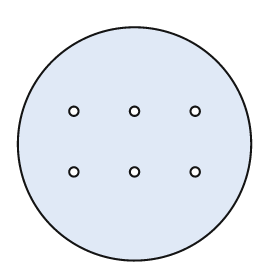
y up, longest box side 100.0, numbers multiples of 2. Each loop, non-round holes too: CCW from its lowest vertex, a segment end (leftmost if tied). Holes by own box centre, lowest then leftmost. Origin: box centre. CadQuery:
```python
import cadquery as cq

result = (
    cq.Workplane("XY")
    .moveTo(0.0, 0.0)
    .circle(50.0)
    .moveTo(-26.0, -12.0)
    .circle(2.0)
    .moveTo(0.0, -12.0)
    .circle(2.0)
    .moveTo(26.0, -12.0)
    .circle(2.0)
    .moveTo(-26.0, 14.0)
    .circle(2.0)
    .moveTo(0.0, 14.0)
    .circle(2.0)
    .moveTo(26.0, 14.0)
    .circle(2.0)
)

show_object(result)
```